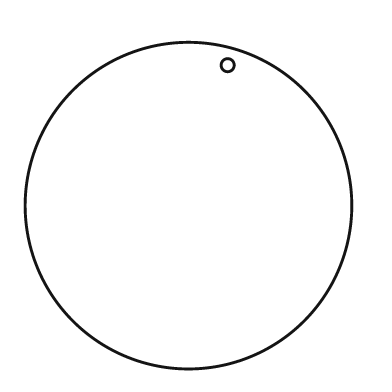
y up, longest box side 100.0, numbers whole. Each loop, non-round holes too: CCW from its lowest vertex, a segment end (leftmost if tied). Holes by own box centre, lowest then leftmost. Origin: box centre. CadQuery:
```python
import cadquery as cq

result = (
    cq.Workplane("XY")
    .moveTo(0.0, 0.0)
    .circle(50.0)
    .moveTo(12.0, 43.0)
    .circle(2.0)
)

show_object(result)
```